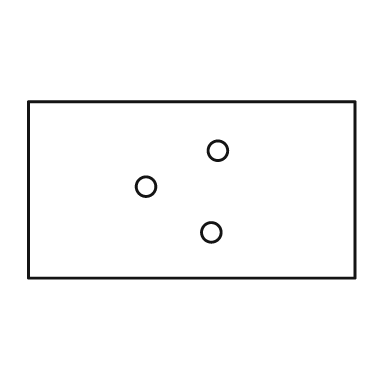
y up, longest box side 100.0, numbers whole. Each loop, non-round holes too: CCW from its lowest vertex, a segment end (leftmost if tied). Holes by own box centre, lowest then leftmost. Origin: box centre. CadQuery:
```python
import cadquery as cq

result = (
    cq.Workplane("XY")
    .moveTo(-50.0, -27.0)
    .lineTo(50.0, -27.0)
    .lineTo(50.0, 27.0)
    .lineTo(-50.0, 27.0)
    .close()
    .moveTo(6.0, -13.0)
    .circle(3.0)
    .moveTo(-14.0, 1.0)
    .circle(3.0)
    .moveTo(8.0, 12.0)
    .circle(3.0)
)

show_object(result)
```